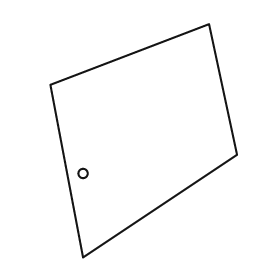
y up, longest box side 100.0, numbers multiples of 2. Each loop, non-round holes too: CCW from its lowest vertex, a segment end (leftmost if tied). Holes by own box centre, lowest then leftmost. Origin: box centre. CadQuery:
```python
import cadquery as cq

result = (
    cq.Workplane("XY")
    .moveTo(-26.0, -50.0)
    .lineTo(40.0, -6.0)
    .lineTo(28.0, 50.0)
    .lineTo(-40.0, 24.0)
    .close()
    .moveTo(-26.0, -14.0)
    .circle(2.0)
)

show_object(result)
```